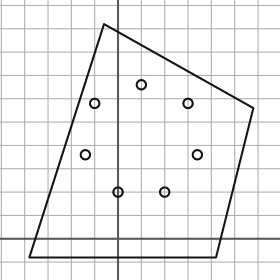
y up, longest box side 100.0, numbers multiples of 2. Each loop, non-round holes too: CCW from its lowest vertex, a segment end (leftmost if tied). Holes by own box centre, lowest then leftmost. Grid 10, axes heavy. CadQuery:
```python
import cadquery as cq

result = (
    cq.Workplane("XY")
    .moveTo(-38.0, -8.0)
    .lineTo(42.0, -8.0)
    .lineTo(58.0, 56.0)
    .lineTo(-6.0, 92.0)
    .close()
    .moveTo(0.0, 20.0)
    .circle(2.0)
    .moveTo(20.0, 20.0)
    .circle(2.0)
    .moveTo(-14.0, 36.0)
    .circle(2.0)
    .moveTo(34.0, 36.0)
    .circle(2.0)
    .moveTo(-10.0, 58.0)
    .circle(2.0)
    .moveTo(30.0, 58.0)
    .circle(2.0)
    .moveTo(10.0, 66.0)
    .circle(2.0)
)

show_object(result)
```